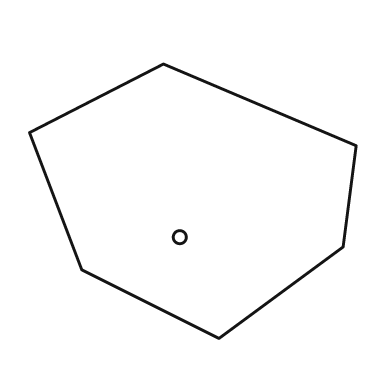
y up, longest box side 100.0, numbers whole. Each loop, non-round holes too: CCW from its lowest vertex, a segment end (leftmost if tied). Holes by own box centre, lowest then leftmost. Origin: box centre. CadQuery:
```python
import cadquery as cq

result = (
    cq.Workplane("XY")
    .moveTo(8.0, -42.0)
    .lineTo(46.0, -14.0)
    .lineTo(50.0, 17.0)
    .lineTo(-9.0, 42.0)
    .lineTo(-50.0, 21.0)
    .lineTo(-34.0, -21.0)
    .close()
    .moveTo(-4.0, -11.0)
    .circle(2.0)
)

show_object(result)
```